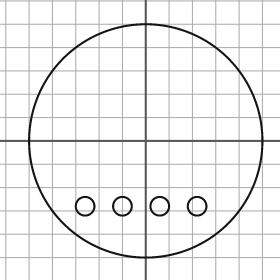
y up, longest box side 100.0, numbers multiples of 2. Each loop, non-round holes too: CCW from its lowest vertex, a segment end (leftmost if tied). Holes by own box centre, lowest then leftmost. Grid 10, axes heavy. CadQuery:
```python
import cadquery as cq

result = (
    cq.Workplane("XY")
    .moveTo(0.0, 0.0)
    .circle(50.0)
    .moveTo(-26.0, -28.0)
    .circle(4.0)
    .moveTo(-10.0, -28.0)
    .circle(4.0)
    .moveTo(6.0, -28.0)
    .circle(4.0)
    .moveTo(22.0, -28.0)
    .circle(4.0)
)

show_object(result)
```